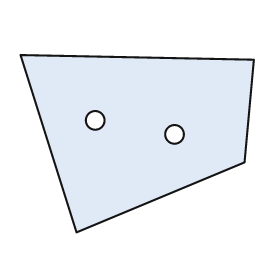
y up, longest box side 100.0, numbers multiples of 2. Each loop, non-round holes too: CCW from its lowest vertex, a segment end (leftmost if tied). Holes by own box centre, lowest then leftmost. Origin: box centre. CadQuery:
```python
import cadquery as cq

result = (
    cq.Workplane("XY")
    .moveTo(-26.0, -38.0)
    .lineTo(46.0, -8.0)
    .lineTo(50.0, 36.0)
    .lineTo(-50.0, 38.0)
    .close()
    .moveTo(16.0, 4.0)
    .circle(4.0)
    .moveTo(-18.0, 10.0)
    .circle(4.0)
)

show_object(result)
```